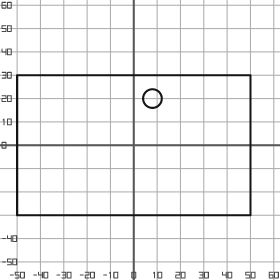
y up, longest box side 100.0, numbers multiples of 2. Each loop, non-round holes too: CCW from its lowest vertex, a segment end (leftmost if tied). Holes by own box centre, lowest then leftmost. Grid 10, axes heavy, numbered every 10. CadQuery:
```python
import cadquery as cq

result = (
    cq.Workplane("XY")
    .moveTo(-50.0, -30.0)
    .lineTo(50.0, -30.0)
    .lineTo(50.0, 30.0)
    .lineTo(-50.0, 30.0)
    .close()
    .moveTo(8.0, 20.0)
    .circle(4.0)
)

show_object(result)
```